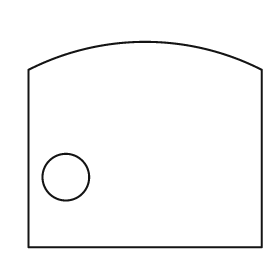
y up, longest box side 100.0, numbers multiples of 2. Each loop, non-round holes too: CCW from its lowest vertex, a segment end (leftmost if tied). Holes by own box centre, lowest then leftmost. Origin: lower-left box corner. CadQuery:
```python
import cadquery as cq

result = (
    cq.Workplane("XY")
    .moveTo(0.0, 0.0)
    .lineTo(100.0, 0.0)
    .lineTo(100.0, 76.0)
    .threePointArc((50.0, 88.0), (0.0, 76.0))
    .close()
    .moveTo(16.0, 30.0)
    .circle(10.0)
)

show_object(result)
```